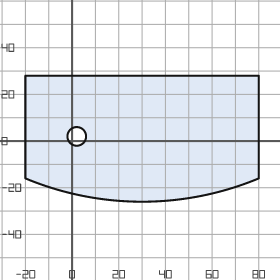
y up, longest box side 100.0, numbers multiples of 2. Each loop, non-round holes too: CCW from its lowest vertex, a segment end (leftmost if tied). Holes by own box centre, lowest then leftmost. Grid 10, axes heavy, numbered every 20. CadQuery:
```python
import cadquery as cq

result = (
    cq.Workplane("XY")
    .moveTo(-20.0, -16.0)
    .threePointArc((30.0, -26.0), (80.0, -16.0))
    .lineTo(80.0, 28.0)
    .lineTo(-20.0, 28.0)
    .close()
    .moveTo(2.0, 2.0)
    .circle(4.0)
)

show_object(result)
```